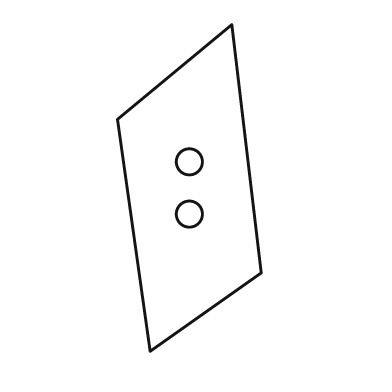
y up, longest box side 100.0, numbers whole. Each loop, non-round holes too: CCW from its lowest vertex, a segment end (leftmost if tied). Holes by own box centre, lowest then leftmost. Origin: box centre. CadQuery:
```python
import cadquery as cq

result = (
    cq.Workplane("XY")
    .moveTo(-12.0, -50.0)
    .lineTo(22.0, -26.0)
    .lineTo(13.0, 50.0)
    .lineTo(-22.0, 21.0)
    .close()
    .moveTo(0.0, -8.0)
    .circle(4.0)
    .moveTo(0.0, 8.0)
    .circle(4.0)
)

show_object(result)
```